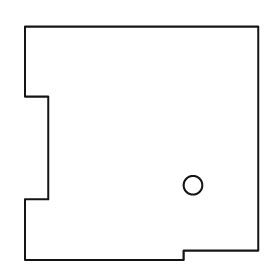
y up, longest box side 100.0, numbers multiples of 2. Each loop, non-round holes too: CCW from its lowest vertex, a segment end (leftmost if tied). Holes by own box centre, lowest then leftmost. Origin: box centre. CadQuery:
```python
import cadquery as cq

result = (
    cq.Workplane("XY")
    .moveTo(-50.0, -50.0)
    .lineTo(18.0, -50.0)
    .lineTo(18.0, -46.0)
    .lineTo(50.0, -46.0)
    .lineTo(50.0, 50.0)
    .lineTo(-50.0, 50.0)
    .lineTo(-50.0, 20.0)
    .lineTo(-40.0, 20.0)
    .lineTo(-40.0, -24.0)
    .lineTo(-50.0, -24.0)
    .close()
    .moveTo(22.0, -18.0)
    .circle(4.0)
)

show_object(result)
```